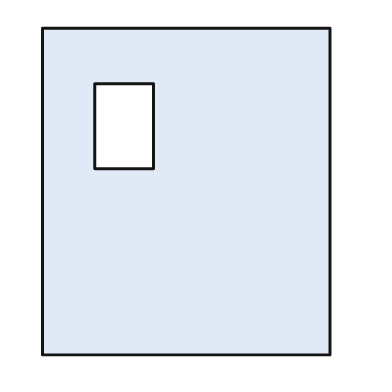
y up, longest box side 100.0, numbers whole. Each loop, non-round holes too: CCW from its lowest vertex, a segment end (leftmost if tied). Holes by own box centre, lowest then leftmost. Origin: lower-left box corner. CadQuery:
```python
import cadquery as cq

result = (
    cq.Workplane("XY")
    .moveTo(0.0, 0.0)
    .lineTo(88.0, 0.0)
    .lineTo(88.0, 100.0)
    .lineTo(0.0, 100.0)
    .close()
    .moveTo(16.0, 57.0)
    .lineTo(34.0, 57.0)
    .lineTo(34.0, 83.0)
    .lineTo(16.0, 83.0)
    .close()
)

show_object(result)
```